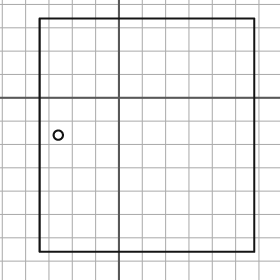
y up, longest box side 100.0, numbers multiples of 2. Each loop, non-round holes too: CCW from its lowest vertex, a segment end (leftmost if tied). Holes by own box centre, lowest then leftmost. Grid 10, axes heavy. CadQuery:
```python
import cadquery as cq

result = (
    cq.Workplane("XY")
    .moveTo(-34.0, -66.0)
    .lineTo(58.0, -66.0)
    .lineTo(58.0, 34.0)
    .lineTo(-34.0, 34.0)
    .close()
    .moveTo(-26.0, -16.0)
    .circle(2.0)
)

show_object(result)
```